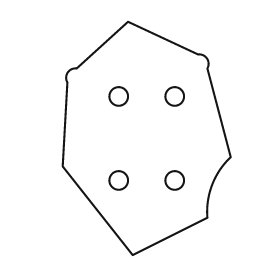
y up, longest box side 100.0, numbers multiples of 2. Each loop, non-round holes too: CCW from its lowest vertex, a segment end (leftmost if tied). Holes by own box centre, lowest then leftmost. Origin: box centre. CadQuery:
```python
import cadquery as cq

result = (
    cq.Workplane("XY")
    .moveTo(-6.0, -50.0)
    .lineTo(26.0, -34.0)
    .threePointArc((28.0, -20.0), (36.0, -8.0))
    .lineTo(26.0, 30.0)
    .threePointArc((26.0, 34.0), (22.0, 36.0))
    .lineTo(-8.0, 50.0)
    .lineTo(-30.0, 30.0)
    .threePointArc((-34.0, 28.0), (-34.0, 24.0))
    .lineTo(-36.0, -12.0)
    .close()
    .moveTo(-12.0, -18.0)
    .circle(4.0)
    .moveTo(12.0, -18.0)
    .circle(4.0)
    .moveTo(-12.0, 18.0)
    .circle(4.0)
    .moveTo(12.0, 18.0)
    .circle(4.0)
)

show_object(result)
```